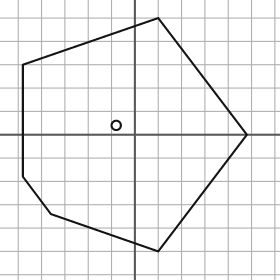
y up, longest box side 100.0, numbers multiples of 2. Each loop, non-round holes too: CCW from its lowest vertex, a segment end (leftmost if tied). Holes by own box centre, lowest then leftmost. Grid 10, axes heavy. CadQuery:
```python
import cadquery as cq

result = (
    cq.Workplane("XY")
    .moveTo(10.0, -50.0)
    .lineTo(48.0, 0.0)
    .lineTo(10.0, 50.0)
    .lineTo(-48.0, 30.0)
    .lineTo(-48.0, -18.0)
    .lineTo(-36.0, -34.0)
    .close()
    .moveTo(-8.0, 4.0)
    .circle(2.0)
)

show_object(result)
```